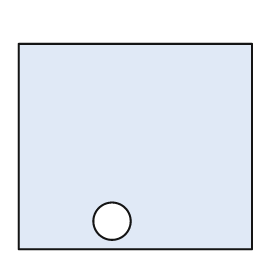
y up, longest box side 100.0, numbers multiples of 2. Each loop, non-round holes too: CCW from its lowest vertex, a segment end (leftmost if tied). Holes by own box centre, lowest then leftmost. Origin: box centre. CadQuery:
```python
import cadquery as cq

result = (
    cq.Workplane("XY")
    .moveTo(-50.0, -44.0)
    .lineTo(50.0, -44.0)
    .lineTo(50.0, 44.0)
    .lineTo(-50.0, 44.0)
    .close()
    .moveTo(-10.0, -32.0)
    .circle(8.0)
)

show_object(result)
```